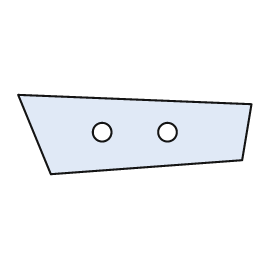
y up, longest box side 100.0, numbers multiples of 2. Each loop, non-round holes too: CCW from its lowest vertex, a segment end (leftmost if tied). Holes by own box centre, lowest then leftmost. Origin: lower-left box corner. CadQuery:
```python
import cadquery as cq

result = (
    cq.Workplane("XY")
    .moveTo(14.0, 0.0)
    .lineTo(96.0, 6.0)
    .lineTo(100.0, 30.0)
    .lineTo(0.0, 34.0)
    .close()
    .moveTo(36.0, 18.0)
    .circle(4.0)
    .moveTo(64.0, 18.0)
    .circle(4.0)
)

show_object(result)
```